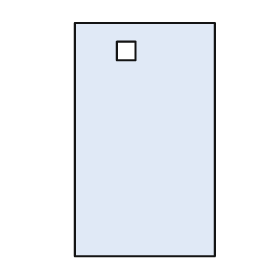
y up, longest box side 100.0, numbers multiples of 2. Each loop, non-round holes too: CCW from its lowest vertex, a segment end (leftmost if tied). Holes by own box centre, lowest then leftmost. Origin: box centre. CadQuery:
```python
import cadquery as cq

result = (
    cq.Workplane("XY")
    .moveTo(-30.0, -50.0)
    .lineTo(30.0, -50.0)
    .lineTo(30.0, 50.0)
    .lineTo(-30.0, 50.0)
    .close()
    .moveTo(-12.0, 34.0)
    .lineTo(-4.0, 34.0)
    .lineTo(-4.0, 42.0)
    .lineTo(-12.0, 42.0)
    .close()
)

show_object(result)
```